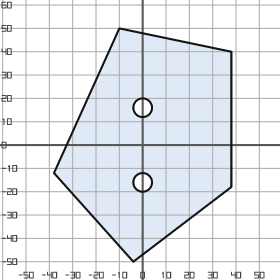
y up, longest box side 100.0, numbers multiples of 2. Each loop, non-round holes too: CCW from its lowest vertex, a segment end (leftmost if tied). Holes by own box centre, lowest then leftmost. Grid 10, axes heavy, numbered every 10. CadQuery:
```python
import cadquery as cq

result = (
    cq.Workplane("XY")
    .moveTo(-4.0, -50.0)
    .lineTo(38.0, -18.0)
    .lineTo(38.0, 40.0)
    .lineTo(-10.0, 50.0)
    .lineTo(-38.0, -12.0)
    .close()
    .moveTo(0.0, -16.0)
    .circle(4.0)
    .moveTo(0.0, 16.0)
    .circle(4.0)
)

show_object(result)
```